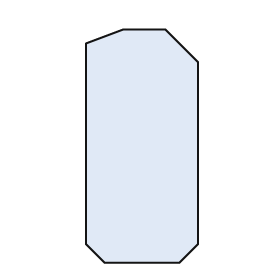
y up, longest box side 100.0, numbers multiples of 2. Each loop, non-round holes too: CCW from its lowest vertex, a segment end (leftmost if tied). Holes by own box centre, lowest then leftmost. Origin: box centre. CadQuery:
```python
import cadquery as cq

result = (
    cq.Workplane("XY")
    .moveTo(-16.0, -50.0)
    .lineTo(16.0, -50.0)
    .lineTo(24.0, -42.0)
    .lineTo(24.0, 36.0)
    .lineTo(10.0, 50.0)
    .lineTo(-8.0, 50.0)
    .lineTo(-24.0, 44.0)
    .lineTo(-24.0, -42.0)
    .close()
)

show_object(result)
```